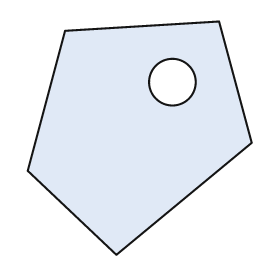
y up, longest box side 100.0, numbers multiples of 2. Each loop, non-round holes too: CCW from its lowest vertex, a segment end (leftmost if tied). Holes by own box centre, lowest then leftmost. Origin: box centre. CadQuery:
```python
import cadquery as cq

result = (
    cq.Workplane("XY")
    .moveTo(-10.0, -50.0)
    .lineTo(48.0, -2.0)
    .lineTo(34.0, 50.0)
    .lineTo(-32.0, 46.0)
    .lineTo(-48.0, -14.0)
    .close()
    .moveTo(14.0, 24.0)
    .circle(10.0)
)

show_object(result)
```